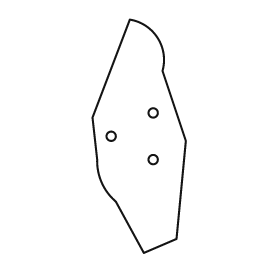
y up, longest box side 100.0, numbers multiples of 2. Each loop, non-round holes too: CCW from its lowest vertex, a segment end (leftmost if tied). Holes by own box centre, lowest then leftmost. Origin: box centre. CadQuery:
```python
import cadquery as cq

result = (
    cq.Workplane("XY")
    .moveTo(2.0, -50.0)
    .lineTo(16.0, -44.0)
    .lineTo(20.0, -2.0)
    .lineTo(10.0, 28.0)
    .threePointArc((8.0, 42.0), (-4.0, 50.0))
    .lineTo(-20.0, 8.0)
    .lineTo(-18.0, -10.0)
    .threePointArc((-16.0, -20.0), (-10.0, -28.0))
    .close()
    .moveTo(6.0, -10.0)
    .circle(2.0)
    .moveTo(-12.0, 0.0)
    .circle(2.0)
    .moveTo(6.0, 10.0)
    .circle(2.0)
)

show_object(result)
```